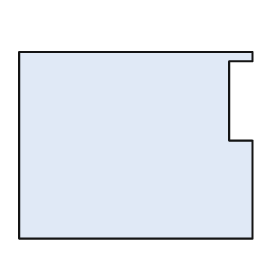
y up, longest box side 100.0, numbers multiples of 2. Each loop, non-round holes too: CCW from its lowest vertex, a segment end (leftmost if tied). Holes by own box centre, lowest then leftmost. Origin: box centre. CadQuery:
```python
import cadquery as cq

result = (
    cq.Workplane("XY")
    .moveTo(-50.0, -40.0)
    .lineTo(50.0, -40.0)
    .lineTo(50.0, 2.0)
    .lineTo(40.0, 2.0)
    .lineTo(40.0, 36.0)
    .lineTo(50.0, 36.0)
    .lineTo(50.0, 40.0)
    .lineTo(-50.0, 40.0)
    .close()
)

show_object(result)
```